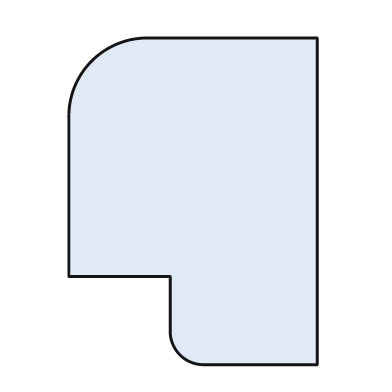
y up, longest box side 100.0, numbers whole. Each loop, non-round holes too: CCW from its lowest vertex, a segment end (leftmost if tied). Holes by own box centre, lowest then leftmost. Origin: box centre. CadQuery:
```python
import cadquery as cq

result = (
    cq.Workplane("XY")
    .moveTo(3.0, -50.0)
    .lineTo(38.0, -50.0)
    .lineTo(38.0, 50.0)
    .lineTo(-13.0, 50.0)
    .threePointArc((-31.0, 43.0), (-38.0, 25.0))
    .lineTo(-38.0, -23.0)
    .lineTo(-7.0, -23.0)
    .lineTo(-7.0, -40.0)
    .threePointArc((-4.0, -47.0), (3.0, -50.0))
    .close()
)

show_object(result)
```